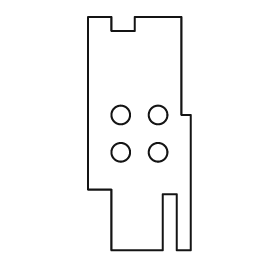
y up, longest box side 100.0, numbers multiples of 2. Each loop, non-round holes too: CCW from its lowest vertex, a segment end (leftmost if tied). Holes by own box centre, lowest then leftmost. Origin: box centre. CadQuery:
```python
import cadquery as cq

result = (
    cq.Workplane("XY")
    .moveTo(-12.0, -50.0)
    .lineTo(10.0, -50.0)
    .lineTo(10.0, -26.0)
    .lineTo(16.0, -26.0)
    .lineTo(16.0, -50.0)
    .lineTo(22.0, -50.0)
    .lineTo(22.0, 8.0)
    .lineTo(18.0, 8.0)
    .lineTo(18.0, 50.0)
    .lineTo(-2.0, 50.0)
    .lineTo(-2.0, 44.0)
    .lineTo(-12.0, 44.0)
    .lineTo(-12.0, 50.0)
    .lineTo(-22.0, 50.0)
    .lineTo(-22.0, -24.0)
    .lineTo(-12.0, -24.0)
    .close()
    .moveTo(-8.0, -8.0)
    .circle(4.0)
    .moveTo(8.0, -8.0)
    .circle(4.0)
    .moveTo(-8.0, 8.0)
    .circle(4.0)
    .moveTo(8.0, 8.0)
    .circle(4.0)
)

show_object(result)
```